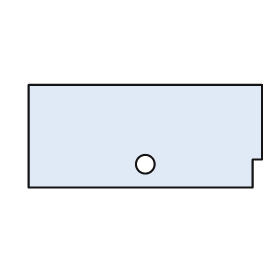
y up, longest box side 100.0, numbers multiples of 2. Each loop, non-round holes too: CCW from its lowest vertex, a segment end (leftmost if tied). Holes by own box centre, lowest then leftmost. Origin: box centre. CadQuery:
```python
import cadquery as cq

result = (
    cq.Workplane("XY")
    .moveTo(-50.0, -22.0)
    .lineTo(46.0, -22.0)
    .lineTo(46.0, -10.0)
    .lineTo(50.0, -10.0)
    .lineTo(50.0, 22.0)
    .lineTo(-50.0, 22.0)
    .close()
    .moveTo(0.0, -12.0)
    .circle(4.0)
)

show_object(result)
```